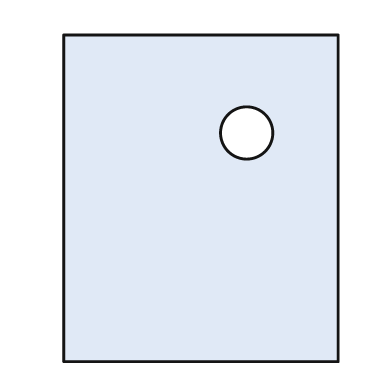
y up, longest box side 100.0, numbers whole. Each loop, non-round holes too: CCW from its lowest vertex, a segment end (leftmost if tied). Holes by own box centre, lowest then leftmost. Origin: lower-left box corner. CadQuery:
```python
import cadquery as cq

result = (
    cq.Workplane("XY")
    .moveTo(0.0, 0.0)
    .lineTo(84.0, 0.0)
    .lineTo(84.0, 100.0)
    .lineTo(0.0, 100.0)
    .close()
    .moveTo(56.0, 70.0)
    .circle(8.0)
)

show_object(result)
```